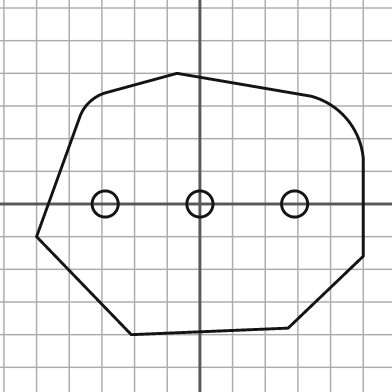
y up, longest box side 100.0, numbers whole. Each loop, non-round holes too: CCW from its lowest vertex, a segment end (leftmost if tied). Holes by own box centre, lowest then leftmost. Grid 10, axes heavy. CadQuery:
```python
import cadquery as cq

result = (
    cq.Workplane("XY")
    .moveTo(-21.0, -40.0)
    .lineTo(27.0, -38.0)
    .lineTo(50.0, -16.0)
    .lineTo(50.0, 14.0)
    .threePointArc((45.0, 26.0), (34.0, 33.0))
    .lineTo(-7.0, 40.0)
    .lineTo(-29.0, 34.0)
    .threePointArc((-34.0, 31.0), (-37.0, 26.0))
    .lineTo(-50.0, -10.0)
    .close()
    .moveTo(-29.0, 0.0)
    .circle(4.0)
    .moveTo(0.0, 0.0)
    .circle(4.0)
    .moveTo(29.0, 0.0)
    .circle(4.0)
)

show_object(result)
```